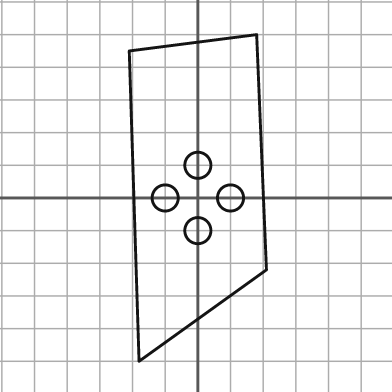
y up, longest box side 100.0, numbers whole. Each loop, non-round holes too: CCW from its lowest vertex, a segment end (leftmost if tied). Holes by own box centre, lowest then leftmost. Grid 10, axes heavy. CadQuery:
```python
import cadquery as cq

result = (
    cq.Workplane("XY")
    .moveTo(-18.0, -50.0)
    .lineTo(21.0, -22.0)
    .lineTo(18.0, 50.0)
    .lineTo(-21.0, 45.0)
    .close()
    .moveTo(0.0, -10.0)
    .circle(4.0)
    .moveTo(-10.0, 0.0)
    .circle(4.0)
    .moveTo(10.0, 0.0)
    .circle(4.0)
    .moveTo(0.0, 10.0)
    .circle(4.0)
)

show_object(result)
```